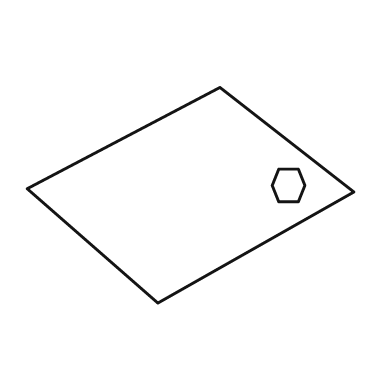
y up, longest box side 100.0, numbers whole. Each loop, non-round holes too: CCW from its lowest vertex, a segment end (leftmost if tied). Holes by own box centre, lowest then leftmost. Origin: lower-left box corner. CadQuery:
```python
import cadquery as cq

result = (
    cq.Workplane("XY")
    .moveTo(40.0, 0.0)
    .lineTo(100.0, 34.0)
    .lineTo(59.0, 66.0)
    .lineTo(0.0, 35.0)
    .close()
    .moveTo(77.0, 31.0)
    .lineTo(83.0, 31.0)
    .lineTo(85.0, 36.0)
    .lineTo(83.0, 41.0)
    .lineTo(77.0, 41.0)
    .lineTo(75.0, 36.0)
    .close()
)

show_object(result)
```